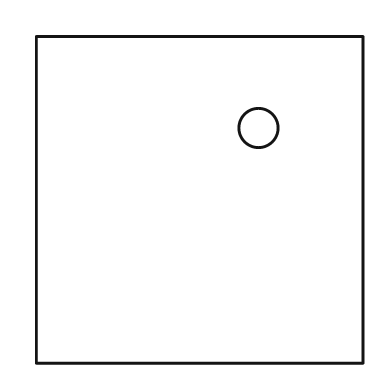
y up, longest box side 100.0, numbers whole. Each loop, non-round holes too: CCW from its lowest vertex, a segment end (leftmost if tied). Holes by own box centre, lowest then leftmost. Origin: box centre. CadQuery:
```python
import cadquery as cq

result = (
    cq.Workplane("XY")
    .moveTo(-50.0, -50.0)
    .lineTo(50.0, -50.0)
    .lineTo(50.0, 50.0)
    .lineTo(-50.0, 50.0)
    .close()
    .moveTo(18.0, 22.0)
    .circle(6.0)
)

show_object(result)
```